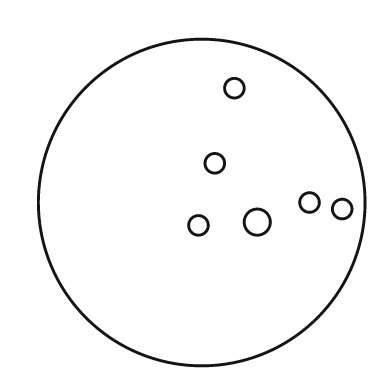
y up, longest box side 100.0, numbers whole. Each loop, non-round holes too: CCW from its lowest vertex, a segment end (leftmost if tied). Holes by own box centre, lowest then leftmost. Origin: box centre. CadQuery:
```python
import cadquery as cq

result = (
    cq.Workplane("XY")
    .moveTo(0.0, 0.0)
    .circle(50.0)
    .moveTo(-1.0, -7.0)
    .circle(3.0)
    .moveTo(17.0, -6.0)
    .circle(4.0)
    .moveTo(43.0, -2.0)
    .circle(3.0)
    .moveTo(33.0, 0.0)
    .circle(3.0)
    .moveTo(4.0, 12.0)
    .circle(3.0)
    .moveTo(10.0, 35.0)
    .circle(3.0)
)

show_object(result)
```